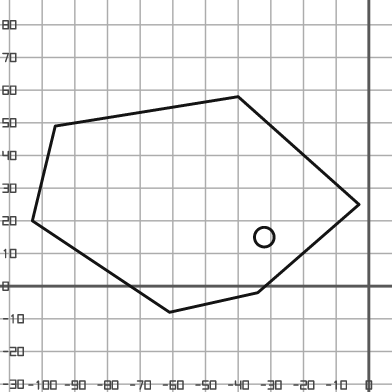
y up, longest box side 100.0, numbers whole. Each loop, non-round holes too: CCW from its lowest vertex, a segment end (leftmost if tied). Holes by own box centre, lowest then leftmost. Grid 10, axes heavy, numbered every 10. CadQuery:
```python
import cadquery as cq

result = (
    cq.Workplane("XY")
    .moveTo(-61.0, -8.0)
    .lineTo(-34.0, -2.0)
    .lineTo(-3.0, 25.0)
    .lineTo(-40.0, 58.0)
    .lineTo(-96.0, 49.0)
    .lineTo(-103.0, 20.0)
    .close()
    .moveTo(-32.0, 15.0)
    .circle(3.0)
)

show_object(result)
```